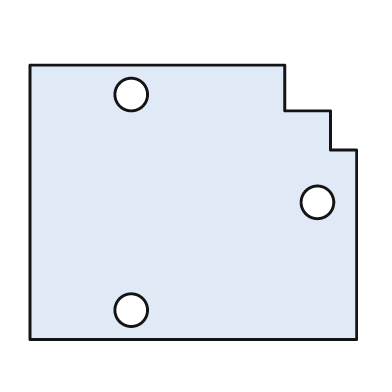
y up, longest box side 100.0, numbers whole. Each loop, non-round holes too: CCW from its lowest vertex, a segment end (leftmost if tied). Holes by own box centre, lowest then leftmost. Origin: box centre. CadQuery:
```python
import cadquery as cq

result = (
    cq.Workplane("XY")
    .moveTo(-50.0, -42.0)
    .lineTo(50.0, -42.0)
    .lineTo(50.0, 16.0)
    .lineTo(42.0, 16.0)
    .lineTo(42.0, 28.0)
    .lineTo(28.0, 28.0)
    .lineTo(28.0, 42.0)
    .lineTo(-50.0, 42.0)
    .close()
    .moveTo(-19.0, -33.0)
    .circle(5.0)
    .moveTo(38.0, 0.0)
    .circle(5.0)
    .moveTo(-19.0, 33.0)
    .circle(5.0)
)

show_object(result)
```